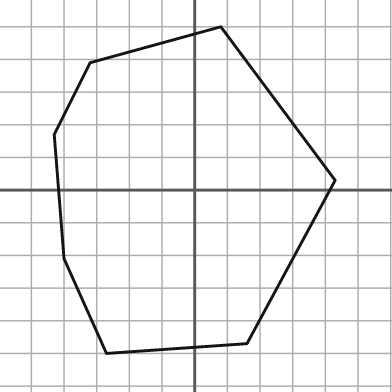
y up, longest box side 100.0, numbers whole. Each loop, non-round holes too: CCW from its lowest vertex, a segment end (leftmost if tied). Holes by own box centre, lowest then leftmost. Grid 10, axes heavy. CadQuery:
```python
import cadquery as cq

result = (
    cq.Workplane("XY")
    .moveTo(-27.0, -50.0)
    .lineTo(16.0, -47.0)
    .lineTo(43.0, 3.0)
    .lineTo(8.0, 50.0)
    .lineTo(-32.0, 39.0)
    .lineTo(-43.0, 17.0)
    .lineTo(-40.0, -21.0)
    .close()
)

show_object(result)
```